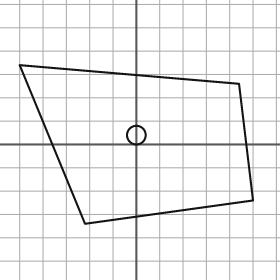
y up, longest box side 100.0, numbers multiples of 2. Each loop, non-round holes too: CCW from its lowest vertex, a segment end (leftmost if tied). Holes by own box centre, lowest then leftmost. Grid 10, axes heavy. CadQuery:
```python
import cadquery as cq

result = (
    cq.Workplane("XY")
    .moveTo(-22.0, -34.0)
    .lineTo(50.0, -24.0)
    .lineTo(44.0, 26.0)
    .lineTo(-50.0, 34.0)
    .close()
    .moveTo(0.0, 4.0)
    .circle(4.0)
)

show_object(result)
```